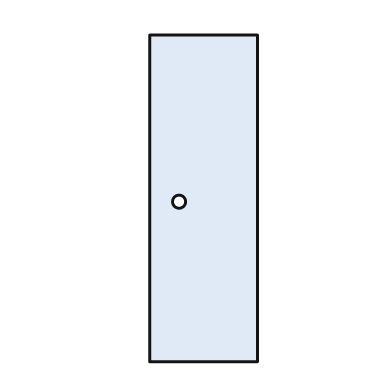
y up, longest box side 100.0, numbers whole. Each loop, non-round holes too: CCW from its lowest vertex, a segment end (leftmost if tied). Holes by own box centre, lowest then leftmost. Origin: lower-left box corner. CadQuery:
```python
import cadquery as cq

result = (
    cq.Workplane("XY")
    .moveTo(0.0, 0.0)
    .lineTo(33.0, 0.0)
    .lineTo(33.0, 100.0)
    .lineTo(0.0, 100.0)
    .close()
    .moveTo(9.0, 49.0)
    .circle(2.0)
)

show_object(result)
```